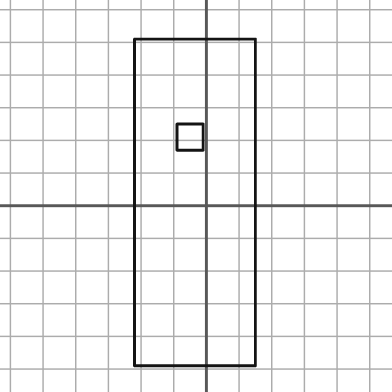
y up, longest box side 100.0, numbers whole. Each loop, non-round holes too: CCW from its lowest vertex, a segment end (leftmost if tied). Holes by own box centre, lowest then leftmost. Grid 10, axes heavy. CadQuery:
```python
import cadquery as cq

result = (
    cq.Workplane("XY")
    .moveTo(-22.0, -49.0)
    .lineTo(15.0, -49.0)
    .lineTo(15.0, 51.0)
    .lineTo(-22.0, 51.0)
    .close()
    .moveTo(-9.0, 17.0)
    .lineTo(-1.0, 17.0)
    .lineTo(-1.0, 25.0)
    .lineTo(-9.0, 25.0)
    .close()
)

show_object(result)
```